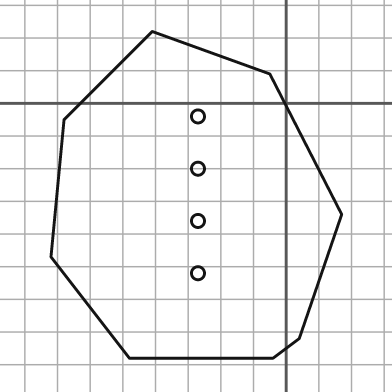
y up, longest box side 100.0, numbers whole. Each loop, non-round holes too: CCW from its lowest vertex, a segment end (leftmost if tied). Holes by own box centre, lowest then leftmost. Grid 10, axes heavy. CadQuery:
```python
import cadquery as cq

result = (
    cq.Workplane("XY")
    .moveTo(-48.0, -78.0)
    .lineTo(-4.0, -78.0)
    .lineTo(4.0, -72.0)
    .lineTo(17.0, -34.0)
    .lineTo(-5.0, 9.0)
    .lineTo(-41.0, 22.0)
    .lineTo(-68.0, -5.0)
    .lineTo(-72.0, -47.0)
    .close()
    .moveTo(-27.0, -52.0)
    .circle(2.0)
    .moveTo(-27.0, -36.0)
    .circle(2.0)
    .moveTo(-27.0, -20.0)
    .circle(2.0)
    .moveTo(-27.0, -4.0)
    .circle(2.0)
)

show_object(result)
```